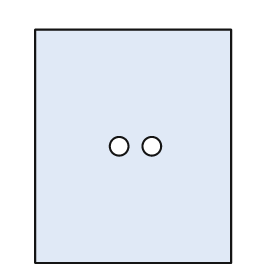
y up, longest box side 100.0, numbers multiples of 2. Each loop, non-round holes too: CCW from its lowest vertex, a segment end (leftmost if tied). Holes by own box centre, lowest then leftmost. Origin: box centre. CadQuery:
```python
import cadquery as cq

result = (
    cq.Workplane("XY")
    .moveTo(-42.0, -50.0)
    .lineTo(42.0, -50.0)
    .lineTo(42.0, 50.0)
    .lineTo(-42.0, 50.0)
    .close()
    .moveTo(-6.0, 0.0)
    .circle(4.0)
    .moveTo(8.0, 0.0)
    .circle(4.0)
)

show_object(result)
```